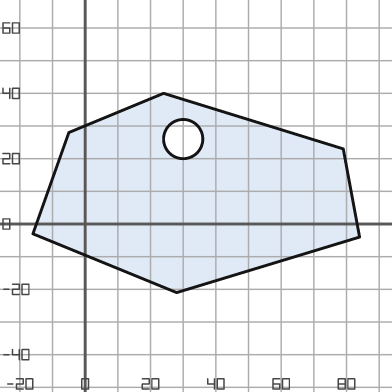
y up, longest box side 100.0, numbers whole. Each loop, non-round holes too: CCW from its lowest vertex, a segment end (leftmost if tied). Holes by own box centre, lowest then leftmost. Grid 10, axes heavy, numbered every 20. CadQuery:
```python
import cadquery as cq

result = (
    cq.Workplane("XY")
    .moveTo(28.0, -21.0)
    .lineTo(84.0, -4.0)
    .lineTo(79.0, 23.0)
    .lineTo(24.0, 40.0)
    .lineTo(-5.0, 28.0)
    .lineTo(-16.0, -3.0)
    .close()
    .moveTo(30.0, 26.0)
    .circle(6.0)
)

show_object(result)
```